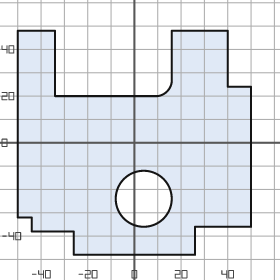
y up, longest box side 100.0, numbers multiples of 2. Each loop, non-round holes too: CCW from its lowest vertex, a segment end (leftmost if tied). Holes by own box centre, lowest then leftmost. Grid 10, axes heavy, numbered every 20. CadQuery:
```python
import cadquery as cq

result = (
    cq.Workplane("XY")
    .moveTo(-26.0, -48.0)
    .lineTo(26.0, -48.0)
    .lineTo(26.0, -36.0)
    .lineTo(50.0, -36.0)
    .lineTo(50.0, 24.0)
    .lineTo(40.0, 24.0)
    .lineTo(40.0, 48.0)
    .lineTo(16.0, 48.0)
    .lineTo(16.0, 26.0)
    .threePointArc((14.0, 22.0), (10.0, 20.0))
    .lineTo(-34.0, 20.0)
    .lineTo(-34.0, 48.0)
    .lineTo(-50.0, 48.0)
    .lineTo(-50.0, -32.0)
    .lineTo(-44.0, -32.0)
    .lineTo(-44.0, -38.0)
    .lineTo(-26.0, -38.0)
    .close()
    .moveTo(4.0, -24.0)
    .circle(12.0)
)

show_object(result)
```